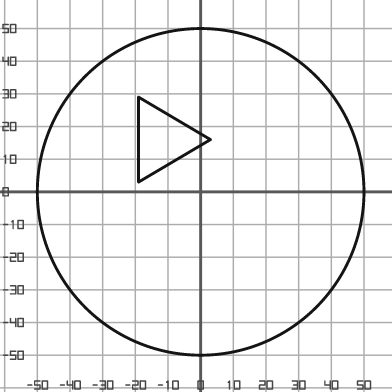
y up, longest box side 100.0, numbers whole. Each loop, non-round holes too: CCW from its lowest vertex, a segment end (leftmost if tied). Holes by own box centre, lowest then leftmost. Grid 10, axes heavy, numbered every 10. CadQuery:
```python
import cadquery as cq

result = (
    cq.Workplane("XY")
    .moveTo(0.0, 0.0)
    .circle(50.0)
    .moveTo(-19.0, 3.0)
    .lineTo(3.0, 16.0)
    .lineTo(-19.0, 29.0)
    .close()
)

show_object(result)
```